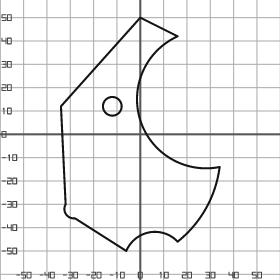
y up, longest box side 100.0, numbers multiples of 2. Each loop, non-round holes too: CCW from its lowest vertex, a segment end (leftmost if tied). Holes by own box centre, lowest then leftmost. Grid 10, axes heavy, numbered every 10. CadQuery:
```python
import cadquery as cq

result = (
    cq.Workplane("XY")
    .moveTo(-6.0, -50.0)
    .threePointArc((4.0, -42.0), (16.0, -46.0))
    .threePointArc((28.0, -32.0), (34.0, -14.0))
    .threePointArc((0.0, 6.0), (16.0, 42.0))
    .lineTo(0.0, 50.0)
    .lineTo(-34.0, 12.0)
    .lineTo(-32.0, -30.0)
    .threePointArc((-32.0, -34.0), (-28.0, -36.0))
    .close()
    .moveTo(-12.0, 12.0)
    .circle(4.0)
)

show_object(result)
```